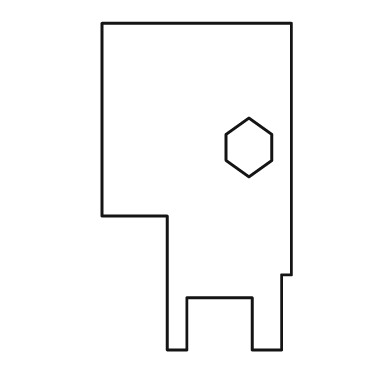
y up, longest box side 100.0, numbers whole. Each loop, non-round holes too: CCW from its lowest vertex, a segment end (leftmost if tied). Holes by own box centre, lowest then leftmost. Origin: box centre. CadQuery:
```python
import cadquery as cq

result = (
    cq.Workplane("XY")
    .moveTo(-9.0, -50.0)
    .lineTo(-3.0, -50.0)
    .lineTo(-3.0, -34.0)
    .lineTo(17.0, -34.0)
    .lineTo(17.0, -50.0)
    .lineTo(26.0, -50.0)
    .lineTo(26.0, -27.0)
    .lineTo(29.0, -27.0)
    .lineTo(29.0, 50.0)
    .lineTo(-29.0, 50.0)
    .lineTo(-29.0, -9.0)
    .lineTo(-9.0, -9.0)
    .close()
    .moveTo(16.0, 3.0)
    .lineTo(23.0, 8.0)
    .lineTo(23.0, 16.0)
    .lineTo(16.0, 21.0)
    .lineTo(9.0, 16.0)
    .lineTo(9.0, 8.0)
    .close()
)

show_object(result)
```